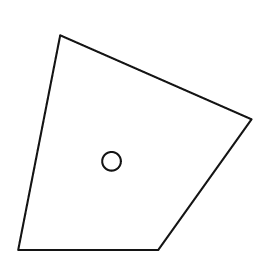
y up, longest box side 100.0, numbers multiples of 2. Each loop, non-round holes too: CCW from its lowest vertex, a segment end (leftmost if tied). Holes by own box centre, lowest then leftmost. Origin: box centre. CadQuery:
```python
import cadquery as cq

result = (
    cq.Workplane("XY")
    .moveTo(-50.0, -46.0)
    .lineTo(10.0, -46.0)
    .lineTo(50.0, 10.0)
    .lineTo(-32.0, 46.0)
    .close()
    .moveTo(-10.0, -8.0)
    .circle(4.0)
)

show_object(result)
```